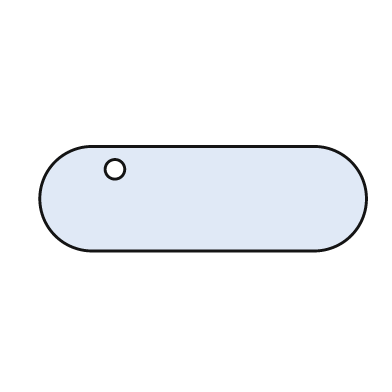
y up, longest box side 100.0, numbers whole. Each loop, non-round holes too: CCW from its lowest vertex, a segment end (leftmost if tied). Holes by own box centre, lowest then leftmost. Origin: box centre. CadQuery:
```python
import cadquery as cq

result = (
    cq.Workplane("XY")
    .moveTo(-34.0, -16.0)
    .lineTo(34.0, -16.0)
    .threePointArc((50.0, 0.0), (34.0, 16.0))
    .lineTo(-34.0, 16.0)
    .threePointArc((-50.0, 0.0), (-34.0, -16.0))
    .close()
    .moveTo(-27.0, 9.0)
    .circle(3.0)
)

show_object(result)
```